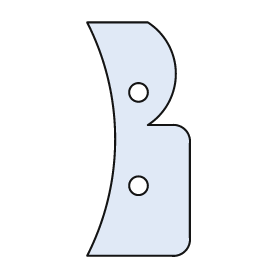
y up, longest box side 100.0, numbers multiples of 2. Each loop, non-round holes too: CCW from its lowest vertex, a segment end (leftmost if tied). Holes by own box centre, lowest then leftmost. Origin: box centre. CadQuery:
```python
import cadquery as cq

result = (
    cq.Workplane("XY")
    .moveTo(-22.0, -50.0)
    .lineTo(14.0, -50.0)
    .threePointArc((20.0, -48.0), (22.0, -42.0))
    .lineTo(22.0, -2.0)
    .threePointArc((20.0, 4.0), (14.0, 6.0))
    .lineTo(4.0, 6.0)
    .threePointArc((16.0, 28.0), (4.0, 50.0))
    .lineTo(-22.0, 50.0)
    .threePointArc((-10.0, 0.0), (-22.0, -50.0))
    .close()
    .moveTo(0.0, -20.0)
    .circle(4.0)
    .moveTo(0.0, 20.0)
    .circle(4.0)
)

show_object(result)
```